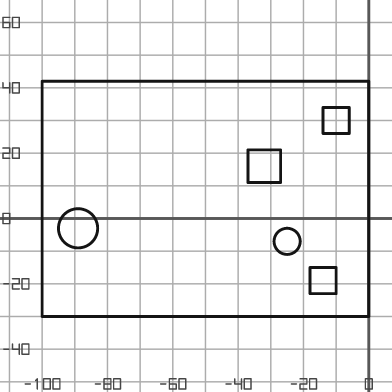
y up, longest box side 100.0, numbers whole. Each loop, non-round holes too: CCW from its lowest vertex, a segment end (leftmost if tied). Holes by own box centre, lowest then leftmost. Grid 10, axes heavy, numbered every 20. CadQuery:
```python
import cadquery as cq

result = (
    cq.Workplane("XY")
    .moveTo(-100.0, -30.0)
    .lineTo(0.0, -30.0)
    .lineTo(0.0, 42.0)
    .lineTo(-100.0, 42.0)
    .close()
    .moveTo(-18.0, -23.0)
    .lineTo(-10.0, -23.0)
    .lineTo(-10.0, -15.0)
    .lineTo(-18.0, -15.0)
    .close()
    .moveTo(-25.0, -7.0)
    .circle(4.0)
    .moveTo(-89.0, -3.0)
    .circle(6.0)
    .moveTo(-37.0, 11.0)
    .lineTo(-27.0, 11.0)
    .lineTo(-27.0, 21.0)
    .lineTo(-37.0, 21.0)
    .close()
    .moveTo(-14.0, 26.0)
    .lineTo(-6.0, 26.0)
    .lineTo(-6.0, 34.0)
    .lineTo(-14.0, 34.0)
    .close()
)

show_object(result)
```